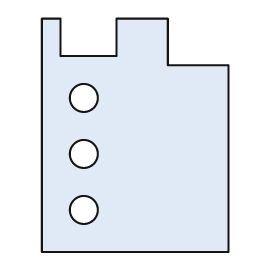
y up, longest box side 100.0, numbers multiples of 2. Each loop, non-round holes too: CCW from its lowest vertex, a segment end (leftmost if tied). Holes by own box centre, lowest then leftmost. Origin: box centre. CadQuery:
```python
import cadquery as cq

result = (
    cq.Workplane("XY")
    .moveTo(-40.0, -50.0)
    .lineTo(40.0, -50.0)
    .lineTo(40.0, 30.0)
    .lineTo(14.0, 30.0)
    .lineTo(14.0, 50.0)
    .lineTo(-8.0, 50.0)
    .lineTo(-8.0, 34.0)
    .lineTo(-32.0, 34.0)
    .lineTo(-32.0, 50.0)
    .lineTo(-40.0, 50.0)
    .close()
    .moveTo(-22.0, -32.0)
    .circle(6.0)
    .moveTo(-22.0, -8.0)
    .circle(6.0)
    .moveTo(-22.0, 16.0)
    .circle(6.0)
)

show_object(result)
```